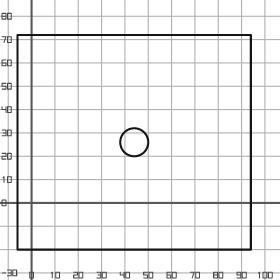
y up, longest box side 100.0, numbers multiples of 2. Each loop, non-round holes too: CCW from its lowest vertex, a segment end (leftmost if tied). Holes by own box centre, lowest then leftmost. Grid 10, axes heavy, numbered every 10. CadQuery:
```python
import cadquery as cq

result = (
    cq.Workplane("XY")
    .moveTo(-6.0, -20.0)
    .lineTo(94.0, -20.0)
    .lineTo(94.0, 72.0)
    .lineTo(-6.0, 72.0)
    .close()
    .moveTo(44.0, 26.0)
    .circle(6.0)
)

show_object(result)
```